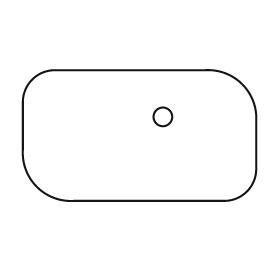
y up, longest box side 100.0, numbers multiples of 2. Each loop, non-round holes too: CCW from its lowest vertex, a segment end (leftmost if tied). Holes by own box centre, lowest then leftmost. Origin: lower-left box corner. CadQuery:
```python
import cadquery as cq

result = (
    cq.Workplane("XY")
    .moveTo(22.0, 0.0)
    .lineTo(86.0, 0.0)
    .threePointArc((96.0, 4.0), (100.0, 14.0))
    .lineTo(100.0, 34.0)
    .threePointArc((94.0, 50.0), (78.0, 56.0))
    .lineTo(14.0, 56.0)
    .threePointArc((4.0, 52.0), (0.0, 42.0))
    .lineTo(0.0, 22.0)
    .threePointArc((6.0, 6.0), (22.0, 0.0))
    .close()
    .moveTo(60.0, 36.0)
    .circle(4.0)
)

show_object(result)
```